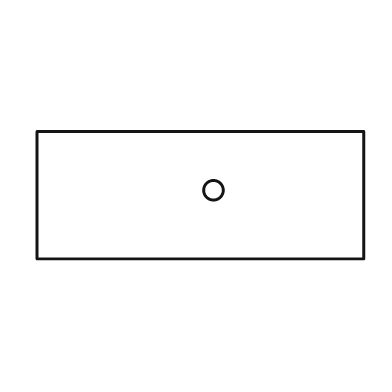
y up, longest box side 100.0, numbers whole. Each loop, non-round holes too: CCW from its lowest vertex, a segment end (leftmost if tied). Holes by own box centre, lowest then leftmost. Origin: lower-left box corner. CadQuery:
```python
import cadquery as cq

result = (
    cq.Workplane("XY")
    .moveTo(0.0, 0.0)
    .lineTo(100.0, 0.0)
    .lineTo(100.0, 39.0)
    .lineTo(0.0, 39.0)
    .close()
    .moveTo(54.0, 21.0)
    .circle(3.0)
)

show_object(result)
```